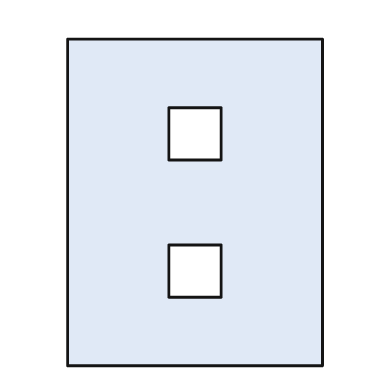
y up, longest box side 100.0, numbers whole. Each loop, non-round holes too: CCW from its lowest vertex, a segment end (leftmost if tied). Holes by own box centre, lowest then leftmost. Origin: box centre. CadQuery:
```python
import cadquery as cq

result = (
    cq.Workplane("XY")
    .moveTo(-39.0, -50.0)
    .lineTo(39.0, -50.0)
    .lineTo(39.0, 50.0)
    .lineTo(-39.0, 50.0)
    .close()
    .moveTo(-8.0, -29.0)
    .lineTo(8.0, -29.0)
    .lineTo(8.0, -13.0)
    .lineTo(-8.0, -13.0)
    .close()
    .moveTo(-8.0, 13.0)
    .lineTo(8.0, 13.0)
    .lineTo(8.0, 29.0)
    .lineTo(-8.0, 29.0)
    .close()
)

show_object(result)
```